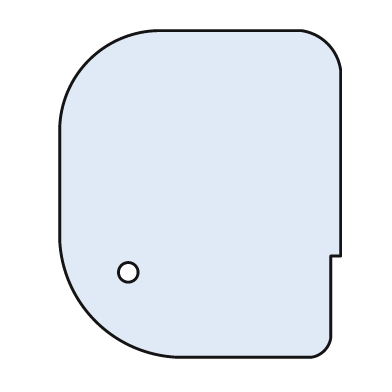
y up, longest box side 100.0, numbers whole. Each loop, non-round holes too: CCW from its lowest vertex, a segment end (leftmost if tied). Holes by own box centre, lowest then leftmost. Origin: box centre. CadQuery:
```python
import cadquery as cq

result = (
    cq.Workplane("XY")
    .moveTo(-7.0, -50.0)
    .lineTo(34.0, -50.0)
    .threePointArc((38.0, -48.0), (40.0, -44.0))
    .lineTo(40.0, -19.0)
    .lineTo(43.0, -19.0)
    .lineTo(43.0, 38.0)
    .threePointArc((39.0, 46.0), (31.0, 50.0))
    .lineTo(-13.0, 50.0)
    .threePointArc((-34.0, 41.0), (-43.0, 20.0))
    .lineTo(-43.0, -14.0)
    .threePointArc((-32.0, -39.0), (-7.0, -50.0))
    .close()
    .moveTo(-22.0, -24.0)
    .circle(3.0)
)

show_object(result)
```